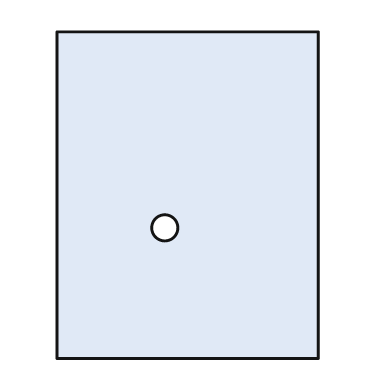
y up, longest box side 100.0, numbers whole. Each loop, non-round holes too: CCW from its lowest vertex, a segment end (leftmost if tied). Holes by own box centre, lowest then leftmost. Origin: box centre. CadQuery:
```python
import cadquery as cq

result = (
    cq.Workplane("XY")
    .moveTo(-40.0, -50.0)
    .lineTo(40.0, -50.0)
    .lineTo(40.0, 50.0)
    .lineTo(-40.0, 50.0)
    .close()
    .moveTo(-7.0, -10.0)
    .circle(4.0)
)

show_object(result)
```